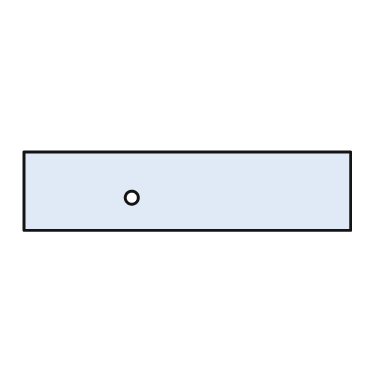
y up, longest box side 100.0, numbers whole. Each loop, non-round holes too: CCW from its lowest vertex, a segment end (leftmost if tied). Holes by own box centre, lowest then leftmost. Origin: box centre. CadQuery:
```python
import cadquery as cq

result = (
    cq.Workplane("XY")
    .moveTo(-50.0, -12.0)
    .lineTo(50.0, -12.0)
    .lineTo(50.0, 12.0)
    .lineTo(-50.0, 12.0)
    .close()
    .moveTo(-17.0, -2.0)
    .circle(2.0)
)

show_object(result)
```